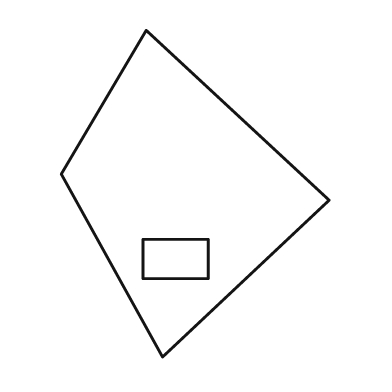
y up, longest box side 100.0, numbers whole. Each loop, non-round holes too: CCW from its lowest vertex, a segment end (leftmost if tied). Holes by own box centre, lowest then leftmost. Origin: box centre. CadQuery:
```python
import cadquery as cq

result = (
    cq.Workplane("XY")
    .moveTo(-10.0, -50.0)
    .lineTo(41.0, -2.0)
    .lineTo(-15.0, 50.0)
    .lineTo(-41.0, 6.0)
    .close()
    .moveTo(-16.0, -26.0)
    .lineTo(4.0, -26.0)
    .lineTo(4.0, -14.0)
    .lineTo(-16.0, -14.0)
    .close()
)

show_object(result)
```